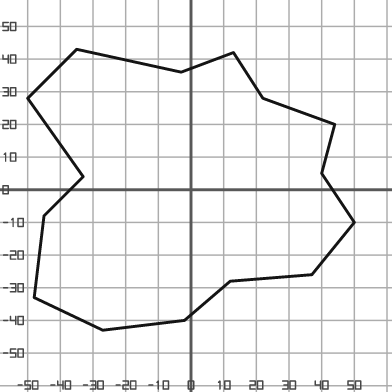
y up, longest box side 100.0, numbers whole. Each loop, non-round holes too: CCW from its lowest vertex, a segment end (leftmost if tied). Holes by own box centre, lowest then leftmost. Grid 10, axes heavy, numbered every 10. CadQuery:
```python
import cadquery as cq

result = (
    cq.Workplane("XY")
    .moveTo(-27.0, -43.0)
    .lineTo(-2.0, -40.0)
    .lineTo(12.0, -28.0)
    .lineTo(37.0, -26.0)
    .lineTo(50.0, -10.0)
    .lineTo(40.0, 5.0)
    .lineTo(44.0, 20.0)
    .lineTo(22.0, 28.0)
    .lineTo(13.0, 42.0)
    .lineTo(-3.0, 36.0)
    .lineTo(-35.0, 43.0)
    .lineTo(-50.0, 28.0)
    .lineTo(-33.0, 4.0)
    .lineTo(-45.0, -8.0)
    .lineTo(-48.0, -33.0)
    .close()
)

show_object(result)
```